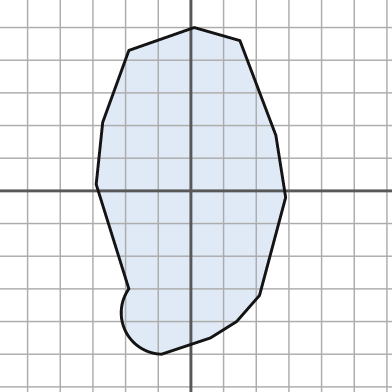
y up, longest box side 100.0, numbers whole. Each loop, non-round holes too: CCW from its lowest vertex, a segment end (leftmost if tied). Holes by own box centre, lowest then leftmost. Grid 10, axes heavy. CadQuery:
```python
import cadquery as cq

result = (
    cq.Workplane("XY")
    .moveTo(-9.0, -50.0)
    .lineTo(6.0, -45.0)
    .lineTo(14.0, -40.0)
    .lineTo(21.0, -32.0)
    .lineTo(29.0, -2.0)
    .lineTo(26.0, 17.0)
    .lineTo(15.0, 46.0)
    .lineTo(1.0, 50.0)
    .lineTo(-19.0, 43.0)
    .lineTo(-27.0, 21.0)
    .lineTo(-29.0, 2.0)
    .lineTo(-19.0, -30.0)
    .threePointArc((-20.0, -43.0), (-9.0, -50.0))
    .close()
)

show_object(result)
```